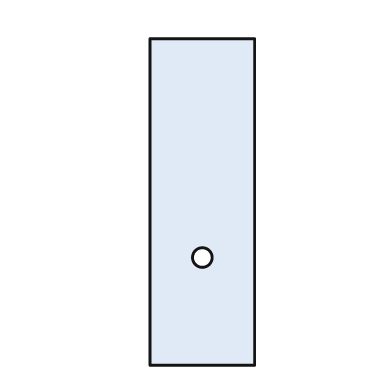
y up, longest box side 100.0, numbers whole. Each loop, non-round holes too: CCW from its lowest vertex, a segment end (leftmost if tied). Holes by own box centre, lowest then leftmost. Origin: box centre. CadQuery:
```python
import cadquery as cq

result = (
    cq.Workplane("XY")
    .moveTo(-16.0, -50.0)
    .lineTo(16.0, -50.0)
    .lineTo(16.0, 50.0)
    .lineTo(-16.0, 50.0)
    .close()
    .moveTo(0.0, -17.0)
    .circle(3.0)
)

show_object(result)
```